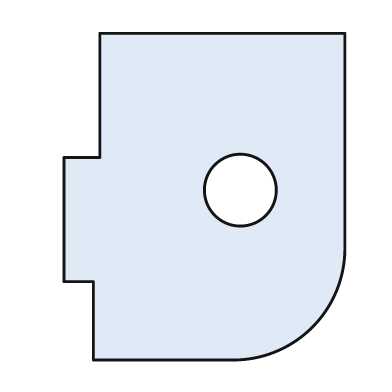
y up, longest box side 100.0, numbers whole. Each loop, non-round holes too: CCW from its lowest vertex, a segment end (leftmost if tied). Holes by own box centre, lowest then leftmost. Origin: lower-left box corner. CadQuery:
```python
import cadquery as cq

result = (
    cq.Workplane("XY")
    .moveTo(9.0, 0.0)
    .lineTo(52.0, 0.0)
    .threePointArc((76.0, 10.0), (86.0, 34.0))
    .lineTo(86.0, 100.0)
    .lineTo(11.0, 100.0)
    .lineTo(11.0, 62.0)
    .lineTo(0.0, 62.0)
    .lineTo(0.0, 24.0)
    .lineTo(9.0, 24.0)
    .close()
    .moveTo(54.0, 52.0)
    .circle(11.0)
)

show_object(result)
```